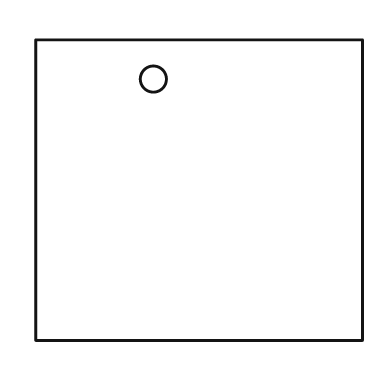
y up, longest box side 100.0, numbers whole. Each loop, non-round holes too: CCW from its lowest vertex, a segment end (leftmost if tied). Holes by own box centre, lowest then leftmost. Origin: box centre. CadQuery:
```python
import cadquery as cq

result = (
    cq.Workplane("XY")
    .moveTo(-50.0, -46.0)
    .lineTo(50.0, -46.0)
    .lineTo(50.0, 46.0)
    .lineTo(-50.0, 46.0)
    .close()
    .moveTo(-14.0, 34.0)
    .circle(4.0)
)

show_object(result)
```